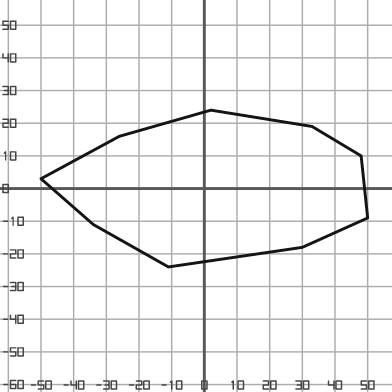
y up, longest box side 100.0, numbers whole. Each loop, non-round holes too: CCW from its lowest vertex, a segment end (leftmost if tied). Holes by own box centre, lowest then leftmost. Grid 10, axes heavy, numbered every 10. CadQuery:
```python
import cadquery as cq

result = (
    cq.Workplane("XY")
    .moveTo(-11.0, -24.0)
    .lineTo(30.0, -18.0)
    .lineTo(50.0, -9.0)
    .lineTo(48.0, 10.0)
    .lineTo(33.0, 19.0)
    .lineTo(2.0, 24.0)
    .lineTo(-26.0, 16.0)
    .lineTo(-50.0, 3.0)
    .lineTo(-34.0, -11.0)
    .close()
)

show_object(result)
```